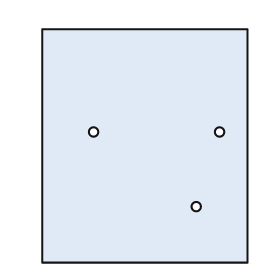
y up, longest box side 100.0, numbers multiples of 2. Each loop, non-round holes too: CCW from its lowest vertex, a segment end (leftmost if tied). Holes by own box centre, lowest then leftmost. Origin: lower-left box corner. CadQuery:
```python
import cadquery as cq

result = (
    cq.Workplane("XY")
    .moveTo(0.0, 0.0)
    .lineTo(88.0, 0.0)
    .lineTo(88.0, 100.0)
    .lineTo(0.0, 100.0)
    .close()
    .moveTo(66.0, 24.0)
    .circle(2.0)
    .moveTo(22.0, 56.0)
    .circle(2.0)
    .moveTo(76.0, 56.0)
    .circle(2.0)
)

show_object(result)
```